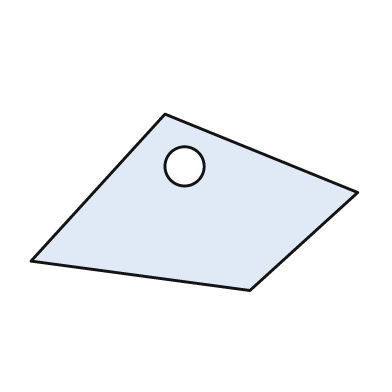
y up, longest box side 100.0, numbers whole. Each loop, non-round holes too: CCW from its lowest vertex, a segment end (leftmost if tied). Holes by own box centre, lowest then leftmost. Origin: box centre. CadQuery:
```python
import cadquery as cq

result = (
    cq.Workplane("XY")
    .moveTo(17.0, -27.0)
    .lineTo(50.0, 3.0)
    .lineTo(-9.0, 27.0)
    .lineTo(-50.0, -18.0)
    .close()
    .moveTo(-3.0, 11.0)
    .circle(6.0)
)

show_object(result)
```